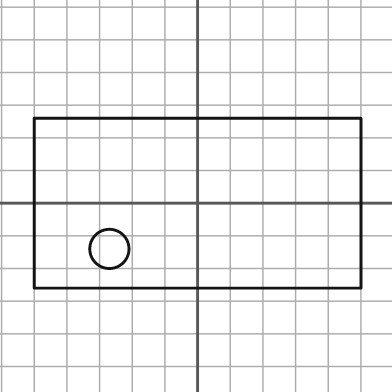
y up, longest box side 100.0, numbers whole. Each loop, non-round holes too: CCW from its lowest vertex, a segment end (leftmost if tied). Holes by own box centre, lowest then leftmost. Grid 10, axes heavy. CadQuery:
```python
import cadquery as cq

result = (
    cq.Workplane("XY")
    .moveTo(-50.0, -26.0)
    .lineTo(50.0, -26.0)
    .lineTo(50.0, 26.0)
    .lineTo(-50.0, 26.0)
    .close()
    .moveTo(-27.0, -14.0)
    .circle(6.0)
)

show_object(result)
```